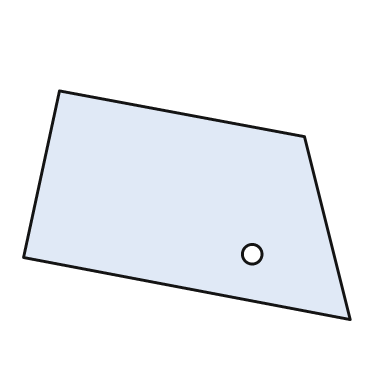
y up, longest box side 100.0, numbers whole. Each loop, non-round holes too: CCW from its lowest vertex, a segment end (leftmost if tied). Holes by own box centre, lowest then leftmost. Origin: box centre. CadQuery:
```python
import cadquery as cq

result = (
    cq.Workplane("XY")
    .moveTo(50.0, -35.0)
    .lineTo(36.0, 21.0)
    .lineTo(-39.0, 35.0)
    .lineTo(-50.0, -16.0)
    .close()
    .moveTo(20.0, -15.0)
    .circle(3.0)
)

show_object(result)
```